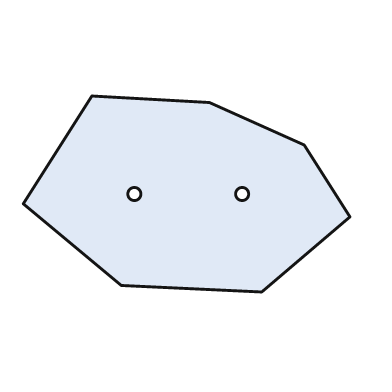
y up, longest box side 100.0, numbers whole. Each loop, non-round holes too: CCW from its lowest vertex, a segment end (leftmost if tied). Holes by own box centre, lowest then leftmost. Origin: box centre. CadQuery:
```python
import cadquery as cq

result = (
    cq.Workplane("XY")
    .moveTo(23.0, -30.0)
    .lineTo(50.0, -7.0)
    .lineTo(36.0, 15.0)
    .lineTo(7.0, 28.0)
    .lineTo(-29.0, 30.0)
    .lineTo(-50.0, -3.0)
    .lineTo(-20.0, -28.0)
    .close()
    .moveTo(-16.0, 0.0)
    .circle(2.0)
    .moveTo(17.0, 0.0)
    .circle(2.0)
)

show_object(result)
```